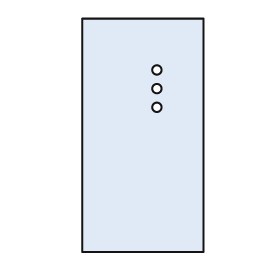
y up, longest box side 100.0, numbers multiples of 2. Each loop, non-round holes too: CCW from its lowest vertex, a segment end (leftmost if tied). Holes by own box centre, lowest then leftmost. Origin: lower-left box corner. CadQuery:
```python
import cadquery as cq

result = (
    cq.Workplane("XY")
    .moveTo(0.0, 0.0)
    .lineTo(52.0, 0.0)
    .lineTo(52.0, 100.0)
    .lineTo(0.0, 100.0)
    .close()
    .moveTo(32.0, 62.0)
    .circle(2.0)
    .moveTo(32.0, 70.0)
    .circle(2.0)
    .moveTo(32.0, 78.0)
    .circle(2.0)
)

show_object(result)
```